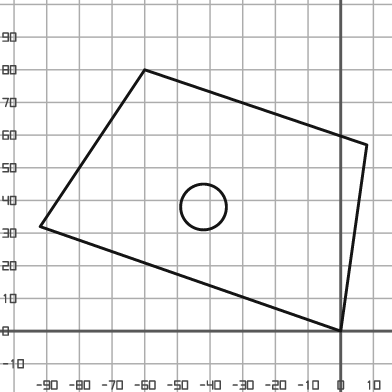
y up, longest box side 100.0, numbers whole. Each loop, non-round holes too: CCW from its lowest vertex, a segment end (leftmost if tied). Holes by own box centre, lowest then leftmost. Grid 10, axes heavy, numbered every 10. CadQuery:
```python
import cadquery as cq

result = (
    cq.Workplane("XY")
    .moveTo(0.0, 0.0)
    .lineTo(8.0, 57.0)
    .lineTo(-60.0, 80.0)
    .lineTo(-92.0, 32.0)
    .close()
    .moveTo(-42.0, 38.0)
    .circle(7.0)
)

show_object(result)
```